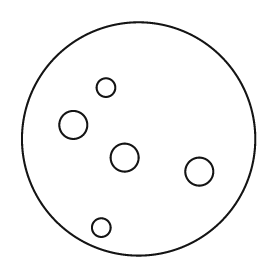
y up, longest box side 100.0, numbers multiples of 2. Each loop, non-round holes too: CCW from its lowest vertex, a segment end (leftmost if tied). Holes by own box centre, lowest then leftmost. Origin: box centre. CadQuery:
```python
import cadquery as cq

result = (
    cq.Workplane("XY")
    .moveTo(0.0, 0.0)
    .circle(50.0)
    .moveTo(-16.0, -38.0)
    .circle(4.0)
    .moveTo(26.0, -14.0)
    .circle(6.0)
    .moveTo(-6.0, -8.0)
    .circle(6.0)
    .moveTo(-28.0, 6.0)
    .circle(6.0)
    .moveTo(-14.0, 22.0)
    .circle(4.0)
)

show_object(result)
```